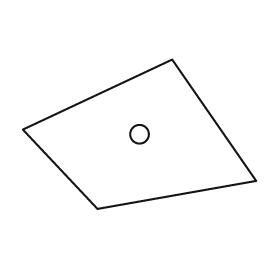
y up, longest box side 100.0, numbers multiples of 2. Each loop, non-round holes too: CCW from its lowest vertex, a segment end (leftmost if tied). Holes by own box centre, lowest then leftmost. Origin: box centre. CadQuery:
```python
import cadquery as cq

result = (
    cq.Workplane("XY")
    .moveTo(-18.0, -32.0)
    .lineTo(50.0, -20.0)
    .lineTo(14.0, 32.0)
    .lineTo(-50.0, 2.0)
    .close()
    .moveTo(0.0, 0.0)
    .circle(4.0)
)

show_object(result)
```